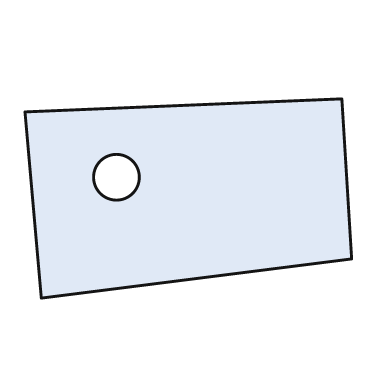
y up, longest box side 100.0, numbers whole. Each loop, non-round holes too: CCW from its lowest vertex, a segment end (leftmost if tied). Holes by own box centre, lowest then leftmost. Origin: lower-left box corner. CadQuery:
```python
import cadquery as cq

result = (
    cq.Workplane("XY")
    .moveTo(5.0, 0.0)
    .lineTo(100.0, 12.0)
    .lineTo(97.0, 61.0)
    .lineTo(0.0, 57.0)
    .close()
    .moveTo(28.0, 37.0)
    .circle(7.0)
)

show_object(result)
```